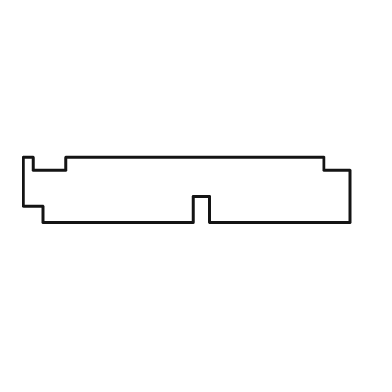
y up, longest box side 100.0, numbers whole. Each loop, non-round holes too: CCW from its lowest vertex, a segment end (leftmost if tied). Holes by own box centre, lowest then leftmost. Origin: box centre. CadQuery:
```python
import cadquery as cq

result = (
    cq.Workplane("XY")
    .moveTo(-44.0, -10.0)
    .lineTo(2.0, -10.0)
    .lineTo(2.0, -2.0)
    .lineTo(7.0, -2.0)
    .lineTo(7.0, -10.0)
    .lineTo(50.0, -10.0)
    .lineTo(50.0, 6.0)
    .lineTo(42.0, 6.0)
    .lineTo(42.0, 10.0)
    .lineTo(-37.0, 10.0)
    .lineTo(-37.0, 6.0)
    .lineTo(-47.0, 6.0)
    .lineTo(-47.0, 10.0)
    .lineTo(-50.0, 10.0)
    .lineTo(-50.0, -5.0)
    .lineTo(-44.0, -5.0)
    .close()
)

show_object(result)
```